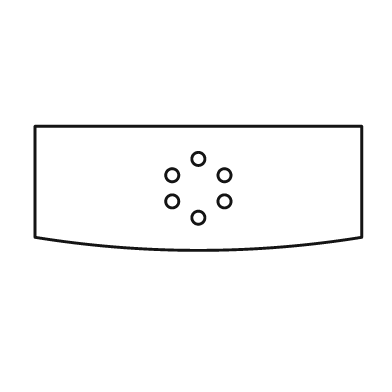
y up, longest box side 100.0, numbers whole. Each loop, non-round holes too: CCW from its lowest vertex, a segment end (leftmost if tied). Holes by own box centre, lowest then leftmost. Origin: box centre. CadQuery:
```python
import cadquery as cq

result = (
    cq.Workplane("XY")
    .moveTo(-50.0, -15.0)
    .threePointArc((0.0, -19.0), (50.0, -15.0))
    .lineTo(50.0, 19.0)
    .lineTo(-50.0, 19.0)
    .close()
    .moveTo(0.0, -9.0)
    .circle(2.0)
    .moveTo(-8.0, -4.0)
    .circle(2.0)
    .moveTo(8.0, -4.0)
    .circle(2.0)
    .moveTo(-8.0, 4.0)
    .circle(2.0)
    .moveTo(8.0, 4.0)
    .circle(2.0)
    .moveTo(0.0, 9.0)
    .circle(2.0)
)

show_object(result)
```